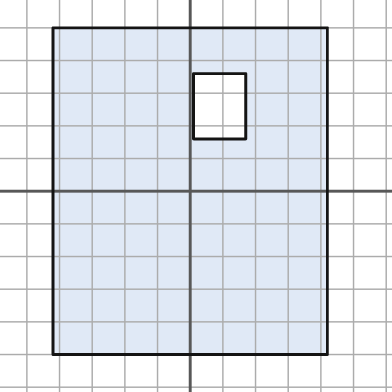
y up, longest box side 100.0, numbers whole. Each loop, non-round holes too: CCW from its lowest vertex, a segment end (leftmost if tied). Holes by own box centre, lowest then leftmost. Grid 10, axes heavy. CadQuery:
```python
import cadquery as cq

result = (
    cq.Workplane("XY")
    .moveTo(-42.0, -50.0)
    .lineTo(42.0, -50.0)
    .lineTo(42.0, 50.0)
    .lineTo(-42.0, 50.0)
    .close()
    .moveTo(1.0, 16.0)
    .lineTo(17.0, 16.0)
    .lineTo(17.0, 36.0)
    .lineTo(1.0, 36.0)
    .close()
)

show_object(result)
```